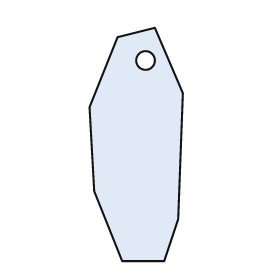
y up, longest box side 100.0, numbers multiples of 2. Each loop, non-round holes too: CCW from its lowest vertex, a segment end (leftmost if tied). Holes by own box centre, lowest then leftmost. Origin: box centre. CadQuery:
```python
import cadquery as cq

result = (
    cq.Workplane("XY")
    .moveTo(-6.0, -50.0)
    .lineTo(12.0, -50.0)
    .lineTo(18.0, -32.0)
    .lineTo(20.0, 22.0)
    .lineTo(8.0, 50.0)
    .lineTo(-8.0, 46.0)
    .lineTo(-20.0, 16.0)
    .lineTo(-18.0, -20.0)
    .close()
    .moveTo(4.0, 36.0)
    .circle(4.0)
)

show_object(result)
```